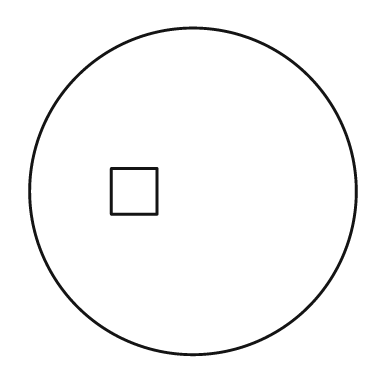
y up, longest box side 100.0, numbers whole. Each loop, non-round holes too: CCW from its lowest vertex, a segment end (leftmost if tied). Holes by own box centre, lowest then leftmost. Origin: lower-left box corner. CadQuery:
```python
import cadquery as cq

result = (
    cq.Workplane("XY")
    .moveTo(50.0, 50.0)
    .circle(50.0)
    .moveTo(25.0, 43.0)
    .lineTo(39.0, 43.0)
    .lineTo(39.0, 57.0)
    .lineTo(25.0, 57.0)
    .close()
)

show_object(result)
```